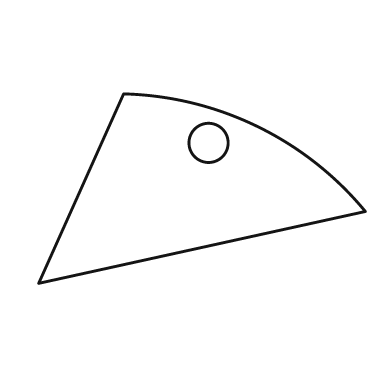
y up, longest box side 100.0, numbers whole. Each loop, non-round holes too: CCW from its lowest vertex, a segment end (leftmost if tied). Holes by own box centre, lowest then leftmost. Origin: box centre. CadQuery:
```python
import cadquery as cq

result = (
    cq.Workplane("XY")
    .moveTo(-50.0, -29.0)
    .lineTo(50.0, -7.0)
    .threePointArc((17.0, 19.0), (-24.0, 29.0))
    .close()
    .moveTo(2.0, 14.0)
    .circle(6.0)
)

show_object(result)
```